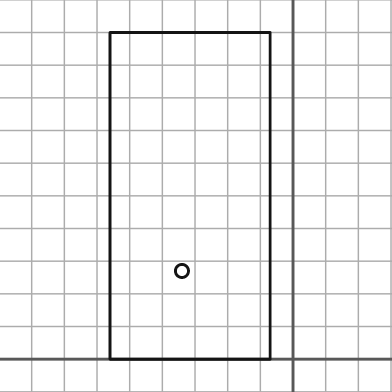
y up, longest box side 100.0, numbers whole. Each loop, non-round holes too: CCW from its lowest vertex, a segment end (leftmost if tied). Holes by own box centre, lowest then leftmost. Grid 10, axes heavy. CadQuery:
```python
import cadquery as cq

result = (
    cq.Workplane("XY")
    .moveTo(-56.0, 0.0)
    .lineTo(-7.0, 0.0)
    .lineTo(-7.0, 100.0)
    .lineTo(-56.0, 100.0)
    .close()
    .moveTo(-34.0, 27.0)
    .circle(2.0)
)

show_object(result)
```